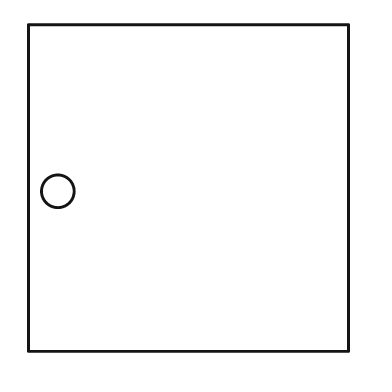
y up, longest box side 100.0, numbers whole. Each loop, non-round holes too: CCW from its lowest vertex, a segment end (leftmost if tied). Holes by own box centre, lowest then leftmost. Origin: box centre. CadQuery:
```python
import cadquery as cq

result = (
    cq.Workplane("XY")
    .moveTo(-49.0, -50.0)
    .lineTo(49.0, -50.0)
    .lineTo(49.0, 50.0)
    .lineTo(-49.0, 50.0)
    .close()
    .moveTo(-40.0, -1.0)
    .circle(5.0)
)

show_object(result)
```